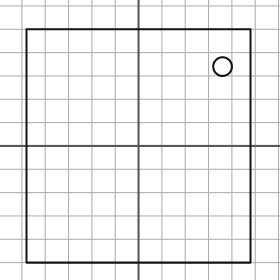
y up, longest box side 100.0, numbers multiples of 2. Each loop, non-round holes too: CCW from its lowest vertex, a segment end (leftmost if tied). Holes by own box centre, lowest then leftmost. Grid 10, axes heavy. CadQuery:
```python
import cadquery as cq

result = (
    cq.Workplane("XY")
    .moveTo(-48.0, -50.0)
    .lineTo(48.0, -50.0)
    .lineTo(48.0, 50.0)
    .lineTo(-48.0, 50.0)
    .close()
    .moveTo(36.0, 34.0)
    .circle(4.0)
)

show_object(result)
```